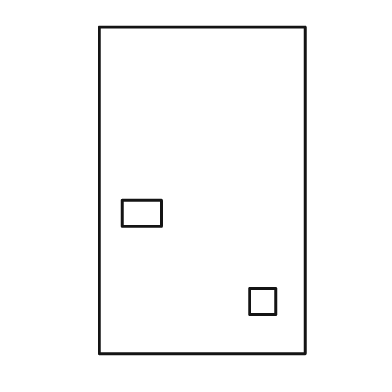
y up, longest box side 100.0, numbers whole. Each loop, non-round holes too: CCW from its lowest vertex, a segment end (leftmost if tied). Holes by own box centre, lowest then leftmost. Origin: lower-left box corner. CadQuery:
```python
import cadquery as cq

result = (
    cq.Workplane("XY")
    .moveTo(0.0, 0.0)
    .lineTo(63.0, 0.0)
    .lineTo(63.0, 100.0)
    .lineTo(0.0, 100.0)
    .close()
    .moveTo(46.0, 12.0)
    .lineTo(54.0, 12.0)
    .lineTo(54.0, 20.0)
    .lineTo(46.0, 20.0)
    .close()
    .moveTo(7.0, 39.0)
    .lineTo(19.0, 39.0)
    .lineTo(19.0, 47.0)
    .lineTo(7.0, 47.0)
    .close()
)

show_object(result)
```